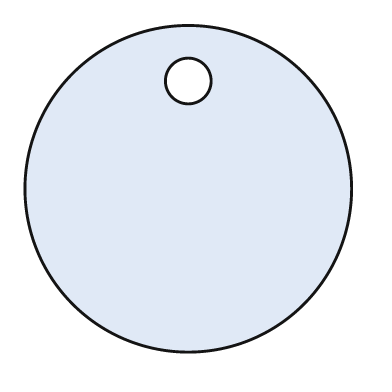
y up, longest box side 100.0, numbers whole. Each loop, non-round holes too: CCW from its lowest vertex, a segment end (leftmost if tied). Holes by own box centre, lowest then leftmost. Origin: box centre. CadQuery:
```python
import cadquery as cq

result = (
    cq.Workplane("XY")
    .moveTo(0.0, 0.0)
    .circle(50.0)
    .moveTo(0.0, 33.0)
    .circle(7.0)
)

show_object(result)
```